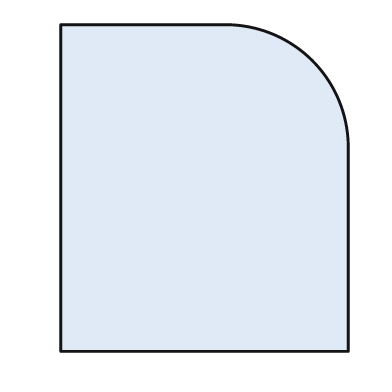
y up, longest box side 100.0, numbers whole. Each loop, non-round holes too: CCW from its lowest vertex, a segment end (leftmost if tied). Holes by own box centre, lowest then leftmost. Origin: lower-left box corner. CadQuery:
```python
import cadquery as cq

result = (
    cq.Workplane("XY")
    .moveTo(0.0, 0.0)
    .lineTo(88.0, 0.0)
    .lineTo(88.0, 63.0)
    .threePointArc((77.0, 89.0), (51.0, 100.0))
    .lineTo(0.0, 100.0)
    .close()
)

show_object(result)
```